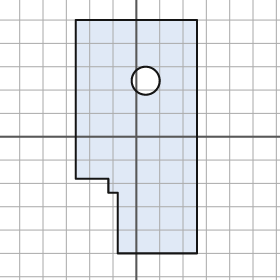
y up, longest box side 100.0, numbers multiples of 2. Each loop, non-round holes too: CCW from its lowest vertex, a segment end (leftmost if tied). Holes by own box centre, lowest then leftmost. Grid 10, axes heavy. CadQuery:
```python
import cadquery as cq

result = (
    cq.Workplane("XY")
    .moveTo(-8.0, -50.0)
    .lineTo(26.0, -50.0)
    .lineTo(26.0, 50.0)
    .lineTo(-26.0, 50.0)
    .lineTo(-26.0, -18.0)
    .lineTo(-12.0, -18.0)
    .lineTo(-12.0, -24.0)
    .lineTo(-8.0, -24.0)
    .close()
    .moveTo(4.0, 24.0)
    .circle(6.0)
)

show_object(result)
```